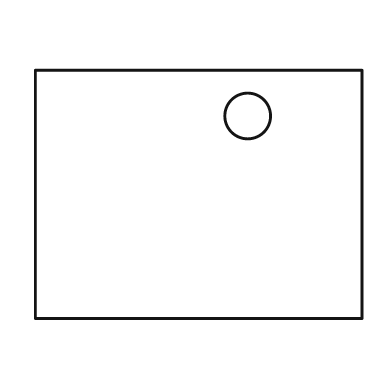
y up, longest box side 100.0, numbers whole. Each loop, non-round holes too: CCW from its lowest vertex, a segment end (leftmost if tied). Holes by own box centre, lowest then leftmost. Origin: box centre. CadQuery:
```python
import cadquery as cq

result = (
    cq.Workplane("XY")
    .moveTo(-50.0, -38.0)
    .lineTo(50.0, -38.0)
    .lineTo(50.0, 38.0)
    .lineTo(-50.0, 38.0)
    .close()
    .moveTo(15.0, 24.0)
    .circle(7.0)
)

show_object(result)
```